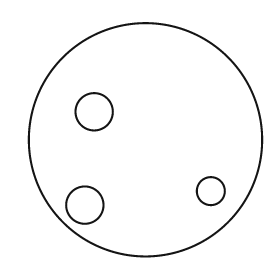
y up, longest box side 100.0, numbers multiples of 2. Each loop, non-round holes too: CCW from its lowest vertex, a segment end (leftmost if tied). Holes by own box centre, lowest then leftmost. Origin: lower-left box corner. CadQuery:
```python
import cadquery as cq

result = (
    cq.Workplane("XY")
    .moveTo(50.0, 50.0)
    .circle(50.0)
    .moveTo(24.0, 22.0)
    .circle(8.0)
    .moveTo(78.0, 28.0)
    .circle(6.0)
    .moveTo(28.0, 62.0)
    .circle(8.0)
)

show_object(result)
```